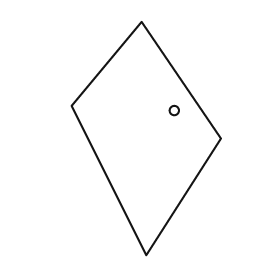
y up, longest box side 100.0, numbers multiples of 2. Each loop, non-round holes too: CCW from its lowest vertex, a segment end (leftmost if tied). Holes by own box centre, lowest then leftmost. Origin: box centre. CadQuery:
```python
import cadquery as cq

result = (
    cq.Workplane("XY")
    .moveTo(0.0, -50.0)
    .lineTo(32.0, 0.0)
    .lineTo(-2.0, 50.0)
    .lineTo(-32.0, 14.0)
    .close()
    .moveTo(12.0, 12.0)
    .circle(2.0)
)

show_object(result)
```